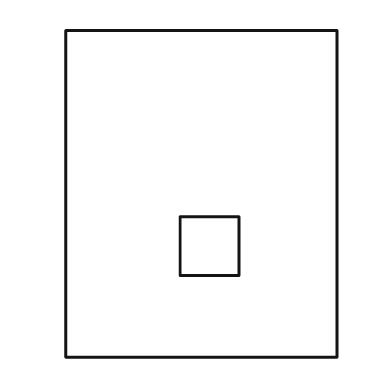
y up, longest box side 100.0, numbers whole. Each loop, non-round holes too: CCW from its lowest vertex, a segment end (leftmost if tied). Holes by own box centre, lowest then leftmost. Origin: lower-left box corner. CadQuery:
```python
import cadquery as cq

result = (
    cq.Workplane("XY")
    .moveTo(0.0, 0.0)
    .lineTo(83.0, 0.0)
    .lineTo(83.0, 100.0)
    .lineTo(0.0, 100.0)
    .close()
    .moveTo(35.0, 25.0)
    .lineTo(53.0, 25.0)
    .lineTo(53.0, 43.0)
    .lineTo(35.0, 43.0)
    .close()
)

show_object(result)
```